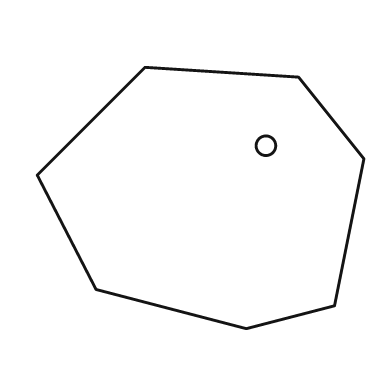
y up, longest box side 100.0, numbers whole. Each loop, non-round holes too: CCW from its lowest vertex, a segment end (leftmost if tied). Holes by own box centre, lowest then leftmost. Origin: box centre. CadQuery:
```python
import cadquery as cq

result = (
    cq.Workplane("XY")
    .moveTo(14.0, -40.0)
    .lineTo(41.0, -33.0)
    .lineTo(50.0, 12.0)
    .lineTo(30.0, 37.0)
    .lineTo(-17.0, 40.0)
    .lineTo(-50.0, 7.0)
    .lineTo(-32.0, -28.0)
    .close()
    .moveTo(20.0, 16.0)
    .circle(3.0)
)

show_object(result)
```